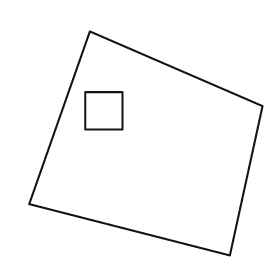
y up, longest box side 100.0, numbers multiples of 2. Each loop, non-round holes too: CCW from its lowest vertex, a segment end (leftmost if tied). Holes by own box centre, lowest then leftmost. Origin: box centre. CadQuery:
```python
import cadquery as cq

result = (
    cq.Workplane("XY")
    .moveTo(36.0, -48.0)
    .lineTo(50.0, 16.0)
    .lineTo(-24.0, 48.0)
    .lineTo(-50.0, -26.0)
    .close()
    .moveTo(-26.0, 6.0)
    .lineTo(-10.0, 6.0)
    .lineTo(-10.0, 22.0)
    .lineTo(-26.0, 22.0)
    .close()
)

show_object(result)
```